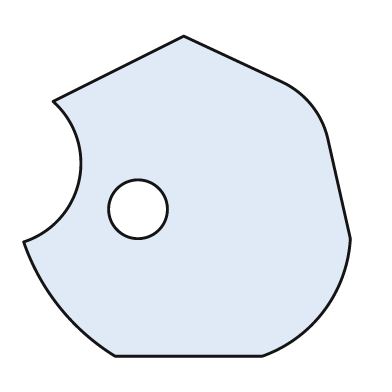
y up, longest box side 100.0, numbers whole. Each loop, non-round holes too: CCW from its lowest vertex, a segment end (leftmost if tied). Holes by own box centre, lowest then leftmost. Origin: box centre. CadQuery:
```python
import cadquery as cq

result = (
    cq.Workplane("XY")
    .moveTo(-22.0, -49.0)
    .lineTo(23.0, -49.0)
    .threePointArc((42.0, -35.0), (50.0, -13.0))
    .lineTo(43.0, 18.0)
    .threePointArc((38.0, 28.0), (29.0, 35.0))
    .lineTo(-1.0, 49.0)
    .lineTo(-41.0, 29.0)
    .threePointArc((-33.0, 5.0), (-50.0, -14.0))
    .threePointArc((-39.0, -34.0), (-22.0, -49.0))
    .close()
    .moveTo(-15.0, -4.0)
    .circle(9.0)
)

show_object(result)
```